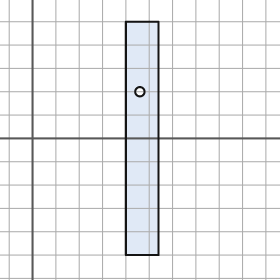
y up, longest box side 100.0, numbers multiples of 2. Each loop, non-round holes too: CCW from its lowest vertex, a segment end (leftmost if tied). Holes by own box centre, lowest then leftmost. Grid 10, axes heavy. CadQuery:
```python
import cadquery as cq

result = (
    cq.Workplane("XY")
    .moveTo(40.0, -50.0)
    .lineTo(54.0, -50.0)
    .lineTo(54.0, 50.0)
    .lineTo(40.0, 50.0)
    .close()
    .moveTo(46.0, 20.0)
    .circle(2.0)
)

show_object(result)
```